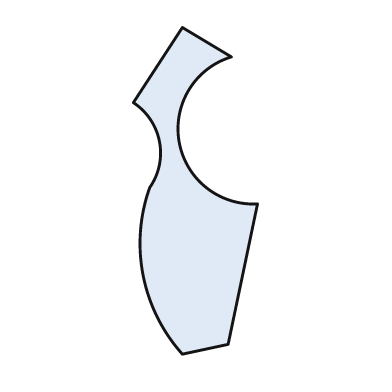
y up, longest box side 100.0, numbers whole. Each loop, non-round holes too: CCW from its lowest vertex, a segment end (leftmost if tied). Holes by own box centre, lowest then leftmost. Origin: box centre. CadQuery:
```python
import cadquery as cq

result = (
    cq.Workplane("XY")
    .moveTo(-4.0, -50.0)
    .lineTo(10.0, -47.0)
    .lineTo(19.0, -4.0)
    .threePointArc((-5.0, 15.0), (11.0, 41.0))
    .lineTo(-4.0, 50.0)
    .lineTo(-19.0, 27.0)
    .threePointArc((-11.0, 15.0), (-14.0, 1.0))
    .threePointArc((-16.0, -26.0), (-4.0, -50.0))
    .close()
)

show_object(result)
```